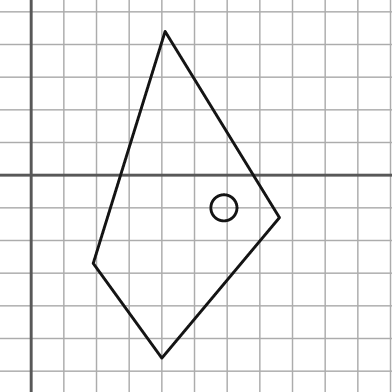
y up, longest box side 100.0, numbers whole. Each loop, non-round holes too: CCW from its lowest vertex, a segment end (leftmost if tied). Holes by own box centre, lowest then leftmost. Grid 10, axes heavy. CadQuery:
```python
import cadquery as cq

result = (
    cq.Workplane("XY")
    .moveTo(40.0, -56.0)
    .lineTo(76.0, -13.0)
    .lineTo(41.0, 44.0)
    .lineTo(19.0, -27.0)
    .close()
    .moveTo(59.0, -10.0)
    .circle(4.0)
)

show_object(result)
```